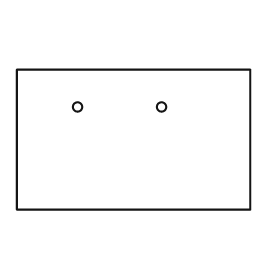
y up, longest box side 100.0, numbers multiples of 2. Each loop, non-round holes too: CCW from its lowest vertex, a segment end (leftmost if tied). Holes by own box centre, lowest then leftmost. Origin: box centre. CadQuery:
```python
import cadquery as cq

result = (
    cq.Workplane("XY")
    .moveTo(-50.0, -30.0)
    .lineTo(50.0, -30.0)
    .lineTo(50.0, 30.0)
    .lineTo(-50.0, 30.0)
    .close()
    .moveTo(-24.0, 14.0)
    .circle(2.0)
    .moveTo(12.0, 14.0)
    .circle(2.0)
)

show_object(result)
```